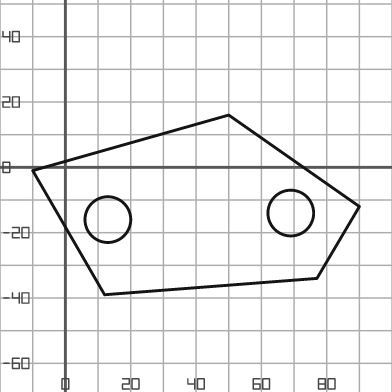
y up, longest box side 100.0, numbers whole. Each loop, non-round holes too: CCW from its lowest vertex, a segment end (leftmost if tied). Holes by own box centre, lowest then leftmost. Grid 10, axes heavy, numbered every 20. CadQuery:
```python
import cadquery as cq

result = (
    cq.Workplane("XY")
    .moveTo(12.0, -39.0)
    .lineTo(77.0, -34.0)
    .lineTo(90.0, -12.0)
    .lineTo(50.0, 16.0)
    .lineTo(-10.0, -1.0)
    .close()
    .moveTo(13.0, -16.0)
    .circle(7.0)
    .moveTo(69.0, -14.0)
    .circle(7.0)
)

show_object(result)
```